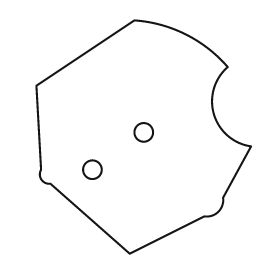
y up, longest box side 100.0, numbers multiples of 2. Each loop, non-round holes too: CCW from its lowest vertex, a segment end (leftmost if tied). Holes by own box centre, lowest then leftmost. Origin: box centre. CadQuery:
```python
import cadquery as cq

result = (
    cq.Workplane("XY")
    .moveTo(-6.0, -50.0)
    .lineTo(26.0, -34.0)
    .threePointArc((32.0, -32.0), (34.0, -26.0))
    .lineTo(46.0, -4.0)
    .threePointArc((30.0, 10.0), (36.0, 30.0))
    .threePointArc((18.0, 44.0), (-4.0, 50.0))
    .lineTo(-46.0, 22.0)
    .lineTo(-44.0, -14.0)
    .threePointArc((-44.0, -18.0), (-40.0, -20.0))
    .close()
    .moveTo(-22.0, -14.0)
    .circle(4.0)
    .moveTo(0.0, 2.0)
    .circle(4.0)
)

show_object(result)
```